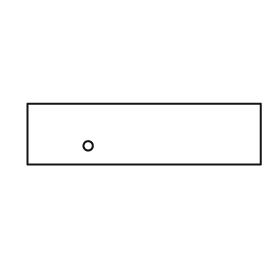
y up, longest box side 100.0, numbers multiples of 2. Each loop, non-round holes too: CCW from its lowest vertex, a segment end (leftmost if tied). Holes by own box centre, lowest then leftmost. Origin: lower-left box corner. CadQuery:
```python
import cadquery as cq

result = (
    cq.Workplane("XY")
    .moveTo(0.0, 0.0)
    .lineTo(100.0, 0.0)
    .lineTo(100.0, 26.0)
    .lineTo(0.0, 26.0)
    .close()
    .moveTo(26.0, 8.0)
    .circle(2.0)
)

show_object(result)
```